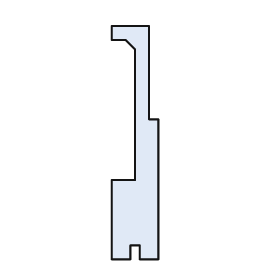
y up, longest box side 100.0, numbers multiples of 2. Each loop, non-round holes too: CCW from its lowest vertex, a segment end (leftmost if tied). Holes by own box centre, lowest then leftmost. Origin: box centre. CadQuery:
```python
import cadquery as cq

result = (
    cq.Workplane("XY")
    .moveTo(-10.0, -50.0)
    .lineTo(-2.0, -50.0)
    .lineTo(-2.0, -44.0)
    .lineTo(2.0, -44.0)
    .lineTo(2.0, -50.0)
    .lineTo(10.0, -50.0)
    .lineTo(10.0, 10.0)
    .lineTo(6.0, 10.0)
    .lineTo(6.0, 50.0)
    .lineTo(-10.0, 50.0)
    .lineTo(-10.0, 44.0)
    .lineTo(-4.0, 44.0)
    .lineTo(0.0, 40.0)
    .lineTo(0.0, -16.0)
    .lineTo(-10.0, -16.0)
    .close()
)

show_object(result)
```